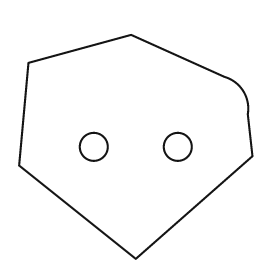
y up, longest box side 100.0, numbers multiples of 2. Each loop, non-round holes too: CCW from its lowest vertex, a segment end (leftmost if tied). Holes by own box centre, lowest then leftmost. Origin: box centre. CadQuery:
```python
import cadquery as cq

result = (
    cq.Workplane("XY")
    .moveTo(0.0, -48.0)
    .lineTo(50.0, -4.0)
    .lineTo(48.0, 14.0)
    .threePointArc((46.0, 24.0), (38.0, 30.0))
    .lineTo(-2.0, 48.0)
    .lineTo(-46.0, 36.0)
    .lineTo(-50.0, -8.0)
    .close()
    .moveTo(-18.0, 0.0)
    .circle(6.0)
    .moveTo(18.0, 0.0)
    .circle(6.0)
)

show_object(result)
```